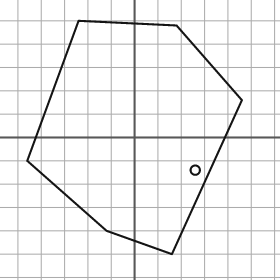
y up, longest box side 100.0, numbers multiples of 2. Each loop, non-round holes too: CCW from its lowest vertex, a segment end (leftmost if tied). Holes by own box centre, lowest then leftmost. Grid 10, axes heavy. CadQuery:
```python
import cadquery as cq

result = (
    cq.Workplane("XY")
    .moveTo(16.0, -50.0)
    .lineTo(46.0, 16.0)
    .lineTo(18.0, 48.0)
    .lineTo(-24.0, 50.0)
    .lineTo(-46.0, -10.0)
    .lineTo(-12.0, -40.0)
    .close()
    .moveTo(26.0, -14.0)
    .circle(2.0)
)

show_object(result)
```